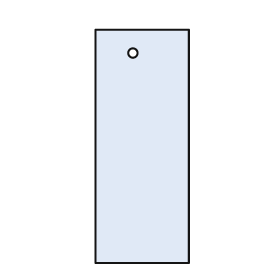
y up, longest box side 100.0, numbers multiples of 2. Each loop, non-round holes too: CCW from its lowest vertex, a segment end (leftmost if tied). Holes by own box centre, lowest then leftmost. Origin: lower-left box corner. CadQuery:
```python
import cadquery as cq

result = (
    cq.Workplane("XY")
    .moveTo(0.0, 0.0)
    .lineTo(40.0, 0.0)
    .lineTo(40.0, 100.0)
    .lineTo(0.0, 100.0)
    .close()
    .moveTo(16.0, 90.0)
    .circle(2.0)
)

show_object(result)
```